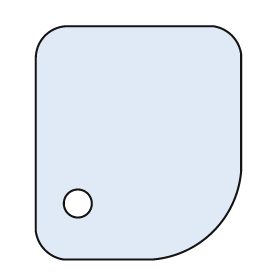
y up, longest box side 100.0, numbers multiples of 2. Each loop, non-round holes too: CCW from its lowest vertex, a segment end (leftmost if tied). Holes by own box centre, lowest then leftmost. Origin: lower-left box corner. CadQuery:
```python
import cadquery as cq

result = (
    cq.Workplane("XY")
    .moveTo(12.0, 0.0)
    .lineTo(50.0, 0.0)
    .threePointArc((76.0, 12.0), (88.0, 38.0))
    .lineTo(88.0, 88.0)
    .threePointArc((84.0, 96.0), (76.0, 100.0))
    .lineTo(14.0, 100.0)
    .threePointArc((4.0, 96.0), (0.0, 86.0))
    .lineTo(0.0, 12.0)
    .threePointArc((4.0, 4.0), (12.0, 0.0))
    .close()
    .moveTo(18.0, 24.0)
    .circle(6.0)
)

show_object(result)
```